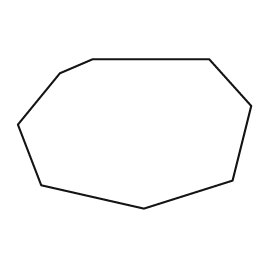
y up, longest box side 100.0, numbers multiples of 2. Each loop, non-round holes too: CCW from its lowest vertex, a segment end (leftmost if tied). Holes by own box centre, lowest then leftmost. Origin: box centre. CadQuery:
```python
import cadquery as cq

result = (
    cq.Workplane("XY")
    .moveTo(4.0, -32.0)
    .lineTo(42.0, -20.0)
    .lineTo(50.0, 12.0)
    .lineTo(32.0, 32.0)
    .lineTo(-18.0, 32.0)
    .lineTo(-32.0, 26.0)
    .lineTo(-50.0, 4.0)
    .lineTo(-40.0, -22.0)
    .close()
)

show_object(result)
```